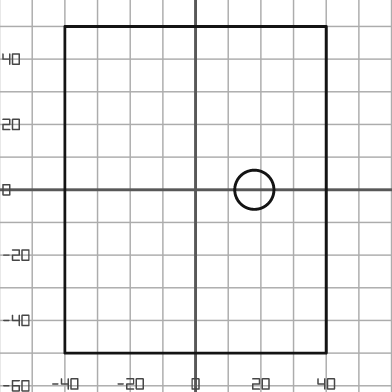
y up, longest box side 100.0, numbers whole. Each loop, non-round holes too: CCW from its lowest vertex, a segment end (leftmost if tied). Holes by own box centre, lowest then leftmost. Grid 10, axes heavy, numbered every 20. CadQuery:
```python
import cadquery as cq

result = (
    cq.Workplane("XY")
    .moveTo(-40.0, -50.0)
    .lineTo(40.0, -50.0)
    .lineTo(40.0, 50.0)
    .lineTo(-40.0, 50.0)
    .close()
    .moveTo(18.0, 0.0)
    .circle(6.0)
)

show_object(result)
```